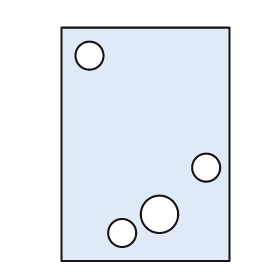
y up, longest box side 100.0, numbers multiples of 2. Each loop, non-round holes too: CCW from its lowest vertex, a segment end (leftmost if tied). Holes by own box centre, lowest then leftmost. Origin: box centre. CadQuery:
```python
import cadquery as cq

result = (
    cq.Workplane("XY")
    .moveTo(-36.0, -50.0)
    .lineTo(36.0, -50.0)
    .lineTo(36.0, 50.0)
    .lineTo(-36.0, 50.0)
    .close()
    .moveTo(-10.0, -38.0)
    .circle(6.0)
    .moveTo(6.0, -30.0)
    .circle(8.0)
    .moveTo(26.0, -10.0)
    .circle(6.0)
    .moveTo(-24.0, 38.0)
    .circle(6.0)
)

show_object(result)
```